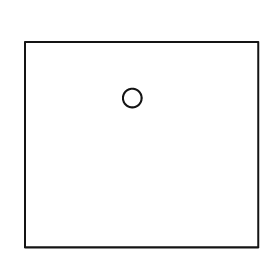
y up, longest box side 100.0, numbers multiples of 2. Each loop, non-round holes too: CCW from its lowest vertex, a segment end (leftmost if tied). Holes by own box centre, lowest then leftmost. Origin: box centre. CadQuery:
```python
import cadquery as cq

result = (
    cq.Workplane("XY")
    .moveTo(-50.0, -44.0)
    .lineTo(50.0, -44.0)
    .lineTo(50.0, 44.0)
    .lineTo(-50.0, 44.0)
    .close()
    .moveTo(-4.0, 20.0)
    .circle(4.0)
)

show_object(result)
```